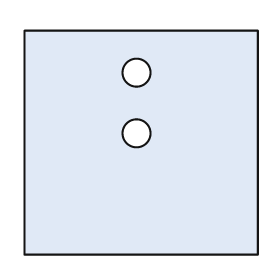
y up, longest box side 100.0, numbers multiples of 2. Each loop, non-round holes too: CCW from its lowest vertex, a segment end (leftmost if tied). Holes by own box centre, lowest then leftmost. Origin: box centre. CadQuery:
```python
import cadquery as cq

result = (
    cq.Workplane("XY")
    .moveTo(-50.0, -48.0)
    .lineTo(50.0, -48.0)
    .lineTo(50.0, 48.0)
    .lineTo(-50.0, 48.0)
    .close()
    .moveTo(-2.0, 4.0)
    .circle(6.0)
    .moveTo(-2.0, 30.0)
    .circle(6.0)
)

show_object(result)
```